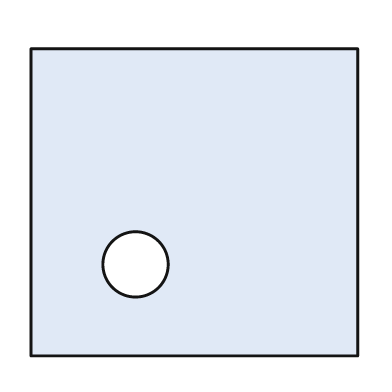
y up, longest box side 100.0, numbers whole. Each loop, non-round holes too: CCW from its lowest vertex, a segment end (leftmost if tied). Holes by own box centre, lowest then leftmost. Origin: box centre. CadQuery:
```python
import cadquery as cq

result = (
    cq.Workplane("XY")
    .moveTo(-50.0, -47.0)
    .lineTo(50.0, -47.0)
    .lineTo(50.0, 47.0)
    .lineTo(-50.0, 47.0)
    .close()
    .moveTo(-18.0, -19.0)
    .circle(10.0)
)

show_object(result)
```